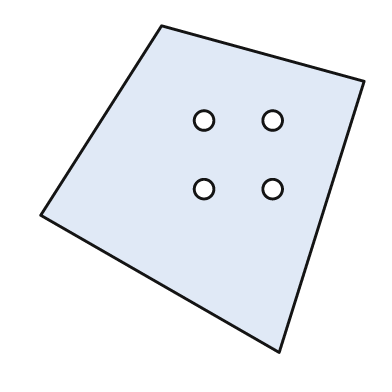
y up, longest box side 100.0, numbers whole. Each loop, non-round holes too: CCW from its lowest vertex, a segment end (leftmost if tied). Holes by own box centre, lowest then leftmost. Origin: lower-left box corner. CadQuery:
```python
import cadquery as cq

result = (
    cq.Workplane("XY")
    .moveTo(73.0, 0.0)
    .lineTo(99.0, 83.0)
    .lineTo(37.0, 100.0)
    .lineTo(0.0, 42.0)
    .close()
    .moveTo(50.0, 50.0)
    .circle(3.0)
    .moveTo(71.0, 50.0)
    .circle(3.0)
    .moveTo(50.0, 71.0)
    .circle(3.0)
    .moveTo(71.0, 71.0)
    .circle(3.0)
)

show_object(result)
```